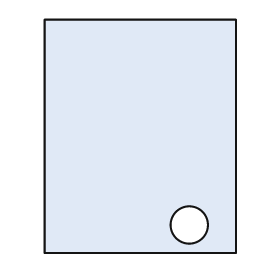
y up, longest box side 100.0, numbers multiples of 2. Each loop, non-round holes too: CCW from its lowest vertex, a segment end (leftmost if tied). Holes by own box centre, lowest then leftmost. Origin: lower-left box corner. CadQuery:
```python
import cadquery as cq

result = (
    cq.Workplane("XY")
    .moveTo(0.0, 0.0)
    .lineTo(82.0, 0.0)
    .lineTo(82.0, 100.0)
    .lineTo(0.0, 100.0)
    .close()
    .moveTo(62.0, 12.0)
    .circle(8.0)
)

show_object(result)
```